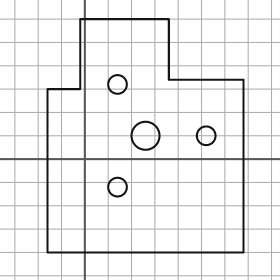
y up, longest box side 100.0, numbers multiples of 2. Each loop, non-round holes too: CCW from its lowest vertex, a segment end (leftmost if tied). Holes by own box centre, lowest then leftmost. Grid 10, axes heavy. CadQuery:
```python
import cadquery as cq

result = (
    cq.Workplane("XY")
    .moveTo(-16.0, -40.0)
    .lineTo(68.0, -40.0)
    .lineTo(68.0, 34.0)
    .lineTo(36.0, 34.0)
    .lineTo(36.0, 60.0)
    .lineTo(-2.0, 60.0)
    .lineTo(-2.0, 30.0)
    .lineTo(-16.0, 30.0)
    .close()
    .moveTo(14.0, -12.0)
    .circle(4.0)
    .moveTo(26.0, 10.0)
    .circle(6.0)
    .moveTo(52.0, 10.0)
    .circle(4.0)
    .moveTo(14.0, 32.0)
    .circle(4.0)
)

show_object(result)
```